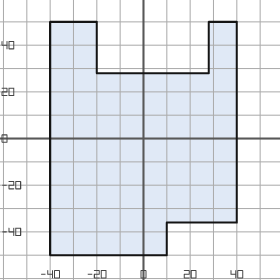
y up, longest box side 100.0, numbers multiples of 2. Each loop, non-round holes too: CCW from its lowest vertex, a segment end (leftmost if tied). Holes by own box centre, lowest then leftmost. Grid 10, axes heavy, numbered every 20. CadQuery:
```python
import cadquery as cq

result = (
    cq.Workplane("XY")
    .moveTo(-40.0, -50.0)
    .lineTo(10.0, -50.0)
    .lineTo(10.0, -36.0)
    .lineTo(40.0, -36.0)
    .lineTo(40.0, 50.0)
    .lineTo(28.0, 50.0)
    .lineTo(28.0, 28.0)
    .lineTo(-20.0, 28.0)
    .lineTo(-20.0, 50.0)
    .lineTo(-40.0, 50.0)
    .close()
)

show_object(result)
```